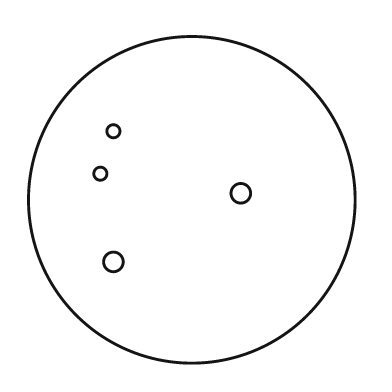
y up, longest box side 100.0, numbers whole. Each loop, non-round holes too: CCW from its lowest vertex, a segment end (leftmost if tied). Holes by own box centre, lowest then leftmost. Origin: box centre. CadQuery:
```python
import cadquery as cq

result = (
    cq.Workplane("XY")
    .moveTo(0.0, 0.0)
    .circle(50.0)
    .moveTo(-24.0, -19.0)
    .circle(3.0)
    .moveTo(15.0, 2.0)
    .circle(3.0)
    .moveTo(-28.0, 8.0)
    .circle(2.0)
    .moveTo(-24.0, 21.0)
    .circle(2.0)
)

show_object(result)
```